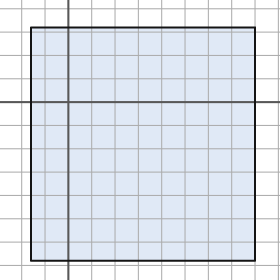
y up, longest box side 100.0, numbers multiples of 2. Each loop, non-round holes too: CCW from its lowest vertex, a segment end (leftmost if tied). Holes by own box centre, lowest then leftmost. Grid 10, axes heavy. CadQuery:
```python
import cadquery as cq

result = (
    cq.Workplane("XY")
    .moveTo(-16.0, -68.0)
    .lineTo(80.0, -68.0)
    .lineTo(80.0, 32.0)
    .lineTo(-16.0, 32.0)
    .close()
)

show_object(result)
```